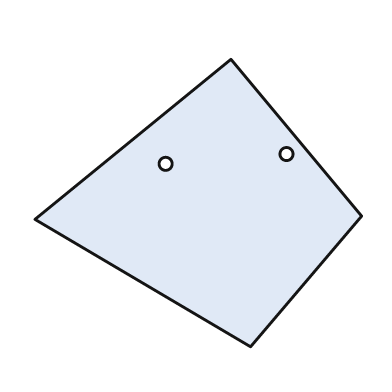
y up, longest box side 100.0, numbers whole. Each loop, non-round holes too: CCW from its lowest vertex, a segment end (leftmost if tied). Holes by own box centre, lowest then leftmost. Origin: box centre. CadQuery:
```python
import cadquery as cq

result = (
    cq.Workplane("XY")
    .moveTo(16.0, -44.0)
    .lineTo(50.0, -4.0)
    .lineTo(10.0, 44.0)
    .lineTo(-50.0, -5.0)
    .close()
    .moveTo(-10.0, 12.0)
    .circle(2.0)
    .moveTo(27.0, 15.0)
    .circle(2.0)
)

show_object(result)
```